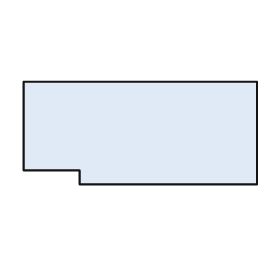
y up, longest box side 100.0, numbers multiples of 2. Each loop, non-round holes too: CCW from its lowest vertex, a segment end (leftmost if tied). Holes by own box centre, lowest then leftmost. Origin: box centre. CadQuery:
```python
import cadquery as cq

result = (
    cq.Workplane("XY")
    .moveTo(-26.0, -22.0)
    .lineTo(50.0, -22.0)
    .lineTo(50.0, 22.0)
    .lineTo(-50.0, 22.0)
    .lineTo(-50.0, -16.0)
    .lineTo(-26.0, -16.0)
    .close()
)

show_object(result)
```